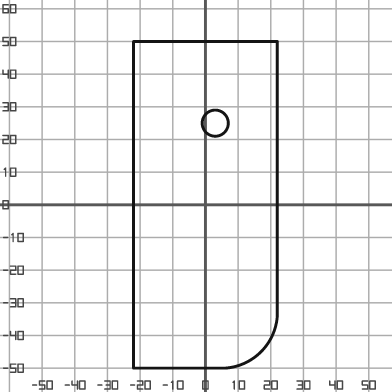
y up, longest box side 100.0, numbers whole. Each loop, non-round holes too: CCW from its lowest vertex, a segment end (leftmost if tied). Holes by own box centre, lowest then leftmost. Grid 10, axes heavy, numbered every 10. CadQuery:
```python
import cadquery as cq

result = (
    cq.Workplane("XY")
    .moveTo(-22.0, -50.0)
    .lineTo(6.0, -50.0)
    .threePointArc((17.0, -45.0), (22.0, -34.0))
    .lineTo(22.0, 50.0)
    .lineTo(-22.0, 50.0)
    .close()
    .moveTo(3.0, 25.0)
    .circle(4.0)
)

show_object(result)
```